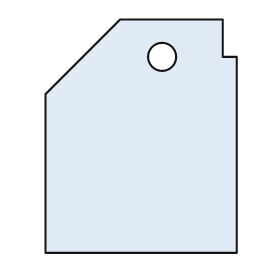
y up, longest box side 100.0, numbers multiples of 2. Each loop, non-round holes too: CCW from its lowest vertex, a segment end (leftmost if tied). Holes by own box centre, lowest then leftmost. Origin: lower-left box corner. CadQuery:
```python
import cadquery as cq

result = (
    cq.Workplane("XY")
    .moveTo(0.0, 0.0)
    .lineTo(82.0, 0.0)
    .lineTo(82.0, 84.0)
    .lineTo(76.0, 84.0)
    .lineTo(76.0, 100.0)
    .lineTo(32.0, 100.0)
    .lineTo(0.0, 68.0)
    .close()
    .moveTo(50.0, 84.0)
    .circle(6.0)
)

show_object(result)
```